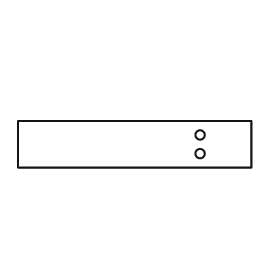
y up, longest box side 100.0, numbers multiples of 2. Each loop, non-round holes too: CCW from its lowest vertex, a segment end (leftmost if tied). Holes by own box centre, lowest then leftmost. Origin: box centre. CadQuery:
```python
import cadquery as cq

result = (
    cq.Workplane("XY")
    .moveTo(-50.0, -10.0)
    .lineTo(50.0, -10.0)
    .lineTo(50.0, 10.0)
    .lineTo(-50.0, 10.0)
    .close()
    .moveTo(28.0, -4.0)
    .circle(2.0)
    .moveTo(28.0, 4.0)
    .circle(2.0)
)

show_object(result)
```